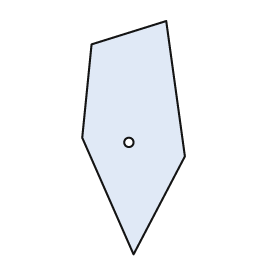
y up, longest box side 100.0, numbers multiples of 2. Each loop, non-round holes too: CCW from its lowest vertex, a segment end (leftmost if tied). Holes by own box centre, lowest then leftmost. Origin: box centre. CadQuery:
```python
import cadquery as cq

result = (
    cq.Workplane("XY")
    .moveTo(0.0, -50.0)
    .lineTo(22.0, -8.0)
    .lineTo(14.0, 50.0)
    .lineTo(-18.0, 40.0)
    .lineTo(-22.0, 0.0)
    .close()
    .moveTo(-2.0, -2.0)
    .circle(2.0)
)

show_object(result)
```